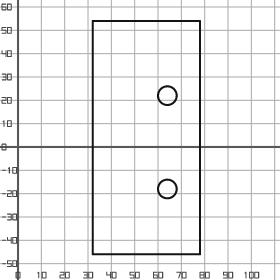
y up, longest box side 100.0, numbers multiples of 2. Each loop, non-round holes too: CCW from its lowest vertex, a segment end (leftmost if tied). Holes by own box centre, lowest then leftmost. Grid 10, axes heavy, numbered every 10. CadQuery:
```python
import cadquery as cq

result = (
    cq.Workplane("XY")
    .moveTo(32.0, -46.0)
    .lineTo(78.0, -46.0)
    .lineTo(78.0, 54.0)
    .lineTo(32.0, 54.0)
    .close()
    .moveTo(64.0, -18.0)
    .circle(4.0)
    .moveTo(64.0, 22.0)
    .circle(4.0)
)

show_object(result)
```